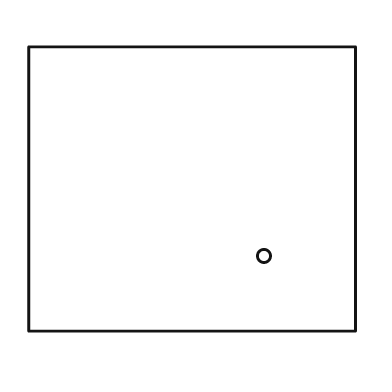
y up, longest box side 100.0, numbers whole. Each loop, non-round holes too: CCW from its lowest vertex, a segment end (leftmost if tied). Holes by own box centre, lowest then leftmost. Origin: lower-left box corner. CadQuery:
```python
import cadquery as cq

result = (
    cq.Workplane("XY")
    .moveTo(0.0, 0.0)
    .lineTo(100.0, 0.0)
    .lineTo(100.0, 87.0)
    .lineTo(0.0, 87.0)
    .close()
    .moveTo(72.0, 23.0)
    .circle(2.0)
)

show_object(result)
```